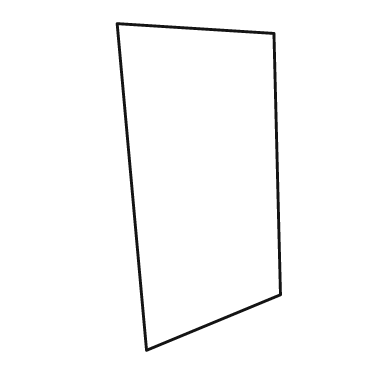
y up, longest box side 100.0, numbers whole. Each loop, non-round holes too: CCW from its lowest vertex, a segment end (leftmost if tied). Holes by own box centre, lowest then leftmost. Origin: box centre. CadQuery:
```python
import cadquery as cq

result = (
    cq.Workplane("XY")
    .moveTo(-16.0, -50.0)
    .lineTo(25.0, -33.0)
    .lineTo(23.0, 47.0)
    .lineTo(-25.0, 50.0)
    .close()
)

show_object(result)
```